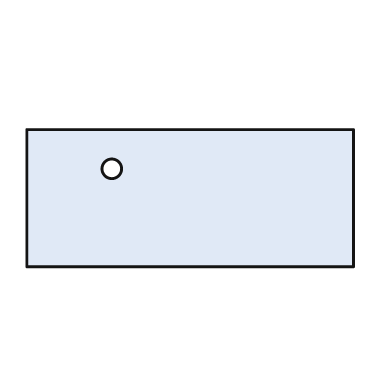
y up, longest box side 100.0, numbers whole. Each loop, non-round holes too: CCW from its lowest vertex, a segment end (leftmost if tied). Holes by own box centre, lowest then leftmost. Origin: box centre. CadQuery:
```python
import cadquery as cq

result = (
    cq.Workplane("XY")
    .moveTo(-50.0, -21.0)
    .lineTo(50.0, -21.0)
    .lineTo(50.0, 21.0)
    .lineTo(-50.0, 21.0)
    .close()
    .moveTo(-24.0, 9.0)
    .circle(3.0)
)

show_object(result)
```